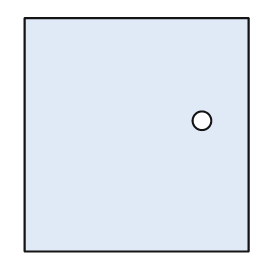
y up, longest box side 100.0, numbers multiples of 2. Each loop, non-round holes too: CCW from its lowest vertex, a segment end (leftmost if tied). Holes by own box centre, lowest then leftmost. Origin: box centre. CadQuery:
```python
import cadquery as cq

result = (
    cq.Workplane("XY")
    .moveTo(-48.0, -50.0)
    .lineTo(48.0, -50.0)
    .lineTo(48.0, 50.0)
    .lineTo(-48.0, 50.0)
    .close()
    .moveTo(28.0, 6.0)
    .circle(4.0)
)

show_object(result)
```